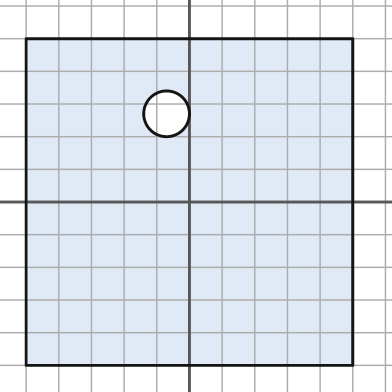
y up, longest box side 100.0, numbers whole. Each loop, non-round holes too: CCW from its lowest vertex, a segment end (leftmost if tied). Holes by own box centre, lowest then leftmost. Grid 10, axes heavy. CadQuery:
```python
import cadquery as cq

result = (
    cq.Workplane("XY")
    .moveTo(-50.0, -50.0)
    .lineTo(50.0, -50.0)
    .lineTo(50.0, 50.0)
    .lineTo(-50.0, 50.0)
    .close()
    .moveTo(-7.0, 27.0)
    .circle(7.0)
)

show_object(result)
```